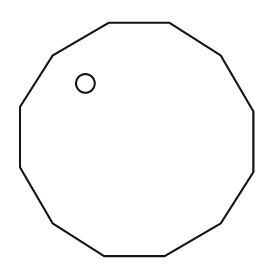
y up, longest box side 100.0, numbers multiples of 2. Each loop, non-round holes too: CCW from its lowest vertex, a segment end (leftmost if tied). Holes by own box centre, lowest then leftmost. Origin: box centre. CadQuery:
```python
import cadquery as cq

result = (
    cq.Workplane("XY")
    .moveTo(-14.0, -50.0)
    .lineTo(12.0, -50.0)
    .lineTo(36.0, -36.0)
    .lineTo(50.0, -14.0)
    .lineTo(50.0, 12.0)
    .lineTo(36.0, 36.0)
    .lineTo(14.0, 50.0)
    .lineTo(-12.0, 50.0)
    .lineTo(-36.0, 36.0)
    .lineTo(-50.0, 14.0)
    .lineTo(-50.0, -12.0)
    .lineTo(-36.0, -36.0)
    .close()
    .moveTo(-22.0, 24.0)
    .circle(4.0)
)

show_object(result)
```